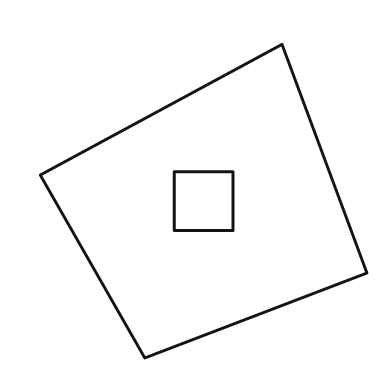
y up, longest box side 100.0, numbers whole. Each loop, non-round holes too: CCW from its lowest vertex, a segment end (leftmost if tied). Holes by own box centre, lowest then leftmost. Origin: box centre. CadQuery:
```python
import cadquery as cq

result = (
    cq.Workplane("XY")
    .moveTo(-18.0, -48.0)
    .lineTo(50.0, -22.0)
    .lineTo(24.0, 48.0)
    .lineTo(-50.0, 8.0)
    .close()
    .moveTo(-9.0, -9.0)
    .lineTo(9.0, -9.0)
    .lineTo(9.0, 9.0)
    .lineTo(-9.0, 9.0)
    .close()
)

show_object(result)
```